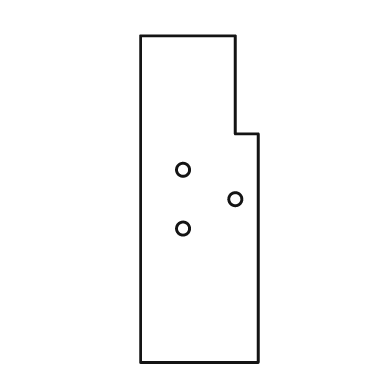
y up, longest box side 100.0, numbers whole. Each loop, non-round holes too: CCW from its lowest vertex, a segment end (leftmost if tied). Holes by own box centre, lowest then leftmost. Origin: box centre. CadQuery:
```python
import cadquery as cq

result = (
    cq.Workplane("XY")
    .moveTo(-18.0, -50.0)
    .lineTo(18.0, -50.0)
    .lineTo(18.0, 20.0)
    .lineTo(11.0, 20.0)
    .lineTo(11.0, 50.0)
    .lineTo(-18.0, 50.0)
    .close()
    .moveTo(-5.0, -9.0)
    .circle(2.0)
    .moveTo(11.0, 0.0)
    .circle(2.0)
    .moveTo(-5.0, 9.0)
    .circle(2.0)
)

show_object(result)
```